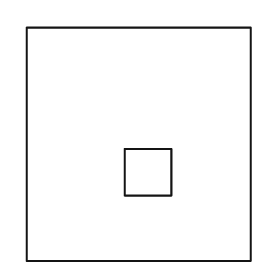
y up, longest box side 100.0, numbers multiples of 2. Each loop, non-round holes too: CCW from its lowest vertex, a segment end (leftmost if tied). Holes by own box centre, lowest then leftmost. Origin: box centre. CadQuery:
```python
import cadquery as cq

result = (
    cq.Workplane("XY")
    .moveTo(-48.0, -50.0)
    .lineTo(48.0, -50.0)
    .lineTo(48.0, 50.0)
    .lineTo(-48.0, 50.0)
    .close()
    .moveTo(-6.0, -22.0)
    .lineTo(14.0, -22.0)
    .lineTo(14.0, -2.0)
    .lineTo(-6.0, -2.0)
    .close()
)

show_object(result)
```